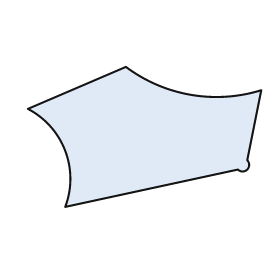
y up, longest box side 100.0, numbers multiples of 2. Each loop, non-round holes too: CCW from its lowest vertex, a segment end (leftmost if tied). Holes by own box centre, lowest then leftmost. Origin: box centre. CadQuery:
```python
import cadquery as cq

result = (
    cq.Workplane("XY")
    .moveTo(-34.0, -30.0)
    .lineTo(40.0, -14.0)
    .threePointArc((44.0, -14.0), (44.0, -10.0))
    .lineTo(50.0, 20.0)
    .threePointArc((20.0, 18.0), (-8.0, 30.0))
    .lineTo(-50.0, 12.0)
    .threePointArc((-34.0, -6.0), (-34.0, -30.0))
    .close()
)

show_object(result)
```